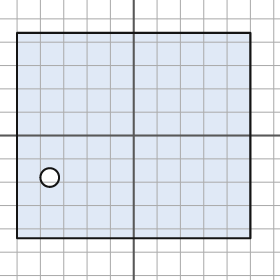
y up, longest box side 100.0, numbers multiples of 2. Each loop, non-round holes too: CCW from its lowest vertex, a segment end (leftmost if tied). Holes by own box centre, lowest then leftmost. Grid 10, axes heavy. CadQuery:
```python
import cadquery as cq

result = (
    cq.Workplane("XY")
    .moveTo(-50.0, -44.0)
    .lineTo(50.0, -44.0)
    .lineTo(50.0, 44.0)
    .lineTo(-50.0, 44.0)
    .close()
    .moveTo(-36.0, -18.0)
    .circle(4.0)
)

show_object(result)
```